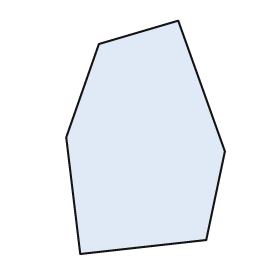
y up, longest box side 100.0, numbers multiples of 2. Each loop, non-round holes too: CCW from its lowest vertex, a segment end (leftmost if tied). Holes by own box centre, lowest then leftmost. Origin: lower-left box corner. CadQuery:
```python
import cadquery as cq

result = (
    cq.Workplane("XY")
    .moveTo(6.0, 0.0)
    .lineTo(60.0, 6.0)
    .lineTo(68.0, 44.0)
    .lineTo(48.0, 100.0)
    .lineTo(14.0, 90.0)
    .lineTo(0.0, 50.0)
    .close()
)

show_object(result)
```